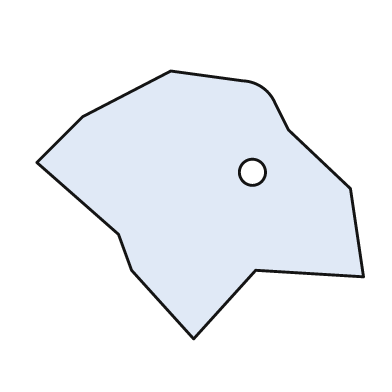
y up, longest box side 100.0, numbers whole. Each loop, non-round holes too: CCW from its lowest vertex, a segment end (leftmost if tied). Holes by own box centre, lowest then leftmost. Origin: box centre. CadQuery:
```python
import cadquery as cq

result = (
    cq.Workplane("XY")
    .moveTo(-2.0, -41.0)
    .lineTo(17.0, -20.0)
    .lineTo(50.0, -22.0)
    .lineTo(46.0, 5.0)
    .lineTo(27.0, 23.0)
    .lineTo(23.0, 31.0)
    .threePointArc((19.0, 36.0), (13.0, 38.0))
    .lineTo(-9.0, 41.0)
    .lineTo(-36.0, 27.0)
    .lineTo(-50.0, 13.0)
    .lineTo(-25.0, -9.0)
    .lineTo(-21.0, -20.0)
    .close()
    .moveTo(16.0, 10.0)
    .circle(4.0)
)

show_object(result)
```